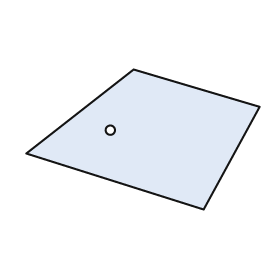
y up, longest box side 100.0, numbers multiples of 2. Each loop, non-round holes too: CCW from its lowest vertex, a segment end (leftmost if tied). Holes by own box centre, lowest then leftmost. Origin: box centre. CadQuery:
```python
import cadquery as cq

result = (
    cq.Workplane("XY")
    .moveTo(26.0, -30.0)
    .lineTo(50.0, 14.0)
    .lineTo(-4.0, 30.0)
    .lineTo(-50.0, -6.0)
    .close()
    .moveTo(-14.0, 4.0)
    .circle(2.0)
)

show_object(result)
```